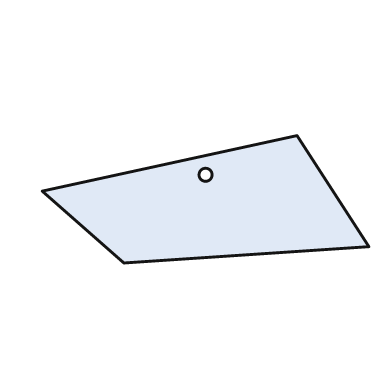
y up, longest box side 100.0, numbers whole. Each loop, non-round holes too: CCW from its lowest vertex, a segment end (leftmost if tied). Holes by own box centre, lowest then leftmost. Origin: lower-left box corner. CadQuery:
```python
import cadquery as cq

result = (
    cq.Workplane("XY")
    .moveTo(25.0, 0.0)
    .lineTo(100.0, 5.0)
    .lineTo(78.0, 39.0)
    .lineTo(0.0, 22.0)
    .close()
    .moveTo(50.0, 27.0)
    .circle(2.0)
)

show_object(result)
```